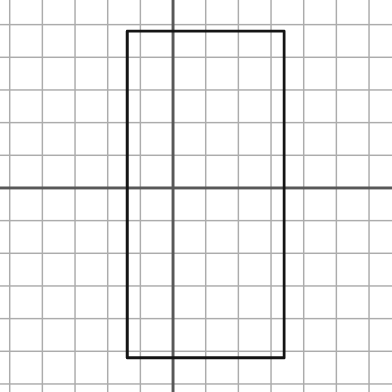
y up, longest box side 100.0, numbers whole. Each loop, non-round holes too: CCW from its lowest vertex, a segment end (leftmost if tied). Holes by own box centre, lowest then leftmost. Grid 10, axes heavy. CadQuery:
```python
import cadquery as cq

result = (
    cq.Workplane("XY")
    .moveTo(-14.0, -52.0)
    .lineTo(34.0, -52.0)
    .lineTo(34.0, 48.0)
    .lineTo(-14.0, 48.0)
    .close()
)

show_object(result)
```